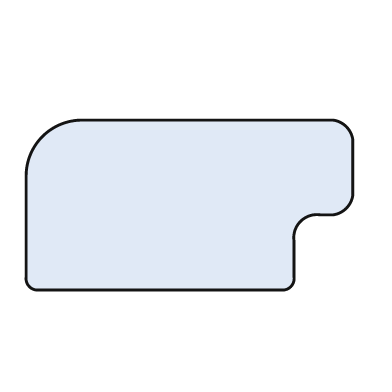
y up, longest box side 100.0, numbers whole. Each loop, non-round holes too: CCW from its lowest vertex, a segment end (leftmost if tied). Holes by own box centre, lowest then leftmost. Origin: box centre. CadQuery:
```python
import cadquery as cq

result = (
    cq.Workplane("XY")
    .moveTo(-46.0, -26.0)
    .lineTo(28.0, -26.0)
    .threePointArc((31.0, -25.0), (32.0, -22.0))
    .lineTo(32.0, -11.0)
    .threePointArc((34.0, -5.0), (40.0, -3.0))
    .lineTo(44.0, -3.0)
    .threePointArc((48.0, -1.0), (50.0, 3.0))
    .lineTo(50.0, 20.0)
    .threePointArc((48.0, 24.0), (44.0, 26.0))
    .lineTo(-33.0, 26.0)
    .threePointArc((-45.0, 21.0), (-50.0, 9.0))
    .lineTo(-50.0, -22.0)
    .threePointArc((-49.0, -25.0), (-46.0, -26.0))
    .close()
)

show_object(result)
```